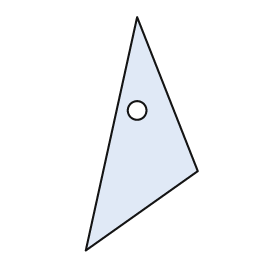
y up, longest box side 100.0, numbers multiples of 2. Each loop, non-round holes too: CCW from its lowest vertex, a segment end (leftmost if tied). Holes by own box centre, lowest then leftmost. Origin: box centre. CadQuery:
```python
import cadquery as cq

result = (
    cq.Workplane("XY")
    .moveTo(-24.0, -50.0)
    .lineTo(24.0, -16.0)
    .lineTo(-2.0, 50.0)
    .close()
    .moveTo(-2.0, 10.0)
    .circle(4.0)
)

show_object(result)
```